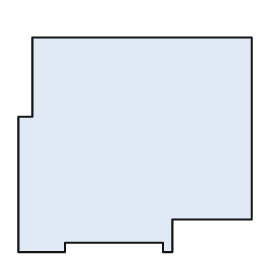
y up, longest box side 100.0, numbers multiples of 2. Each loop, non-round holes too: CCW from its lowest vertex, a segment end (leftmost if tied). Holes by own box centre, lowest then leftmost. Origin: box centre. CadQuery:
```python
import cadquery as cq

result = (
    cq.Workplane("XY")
    .moveTo(-50.0, -46.0)
    .lineTo(-30.0, -46.0)
    .lineTo(-30.0, -42.0)
    .lineTo(12.0, -42.0)
    .lineTo(12.0, -46.0)
    .lineTo(16.0, -46.0)
    .lineTo(16.0, -32.0)
    .lineTo(50.0, -32.0)
    .lineTo(50.0, 46.0)
    .lineTo(-44.0, 46.0)
    .lineTo(-44.0, 12.0)
    .lineTo(-50.0, 12.0)
    .close()
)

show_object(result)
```